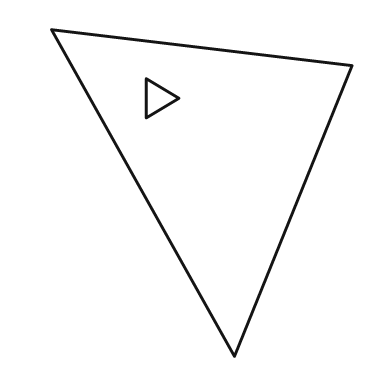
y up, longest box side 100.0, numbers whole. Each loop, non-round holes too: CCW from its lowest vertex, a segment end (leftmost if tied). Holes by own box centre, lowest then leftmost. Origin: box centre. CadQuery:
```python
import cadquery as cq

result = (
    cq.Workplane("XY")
    .moveTo(10.0, -50.0)
    .lineTo(46.0, 39.0)
    .lineTo(-46.0, 50.0)
    .close()
    .moveTo(-17.0, 23.0)
    .lineTo(-7.0, 29.0)
    .lineTo(-17.0, 35.0)
    .close()
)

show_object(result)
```